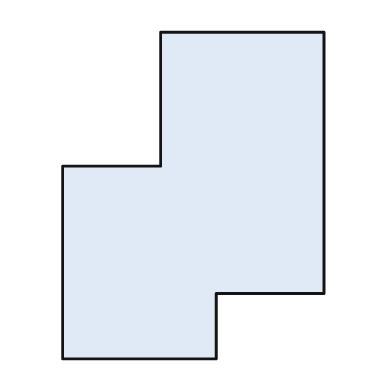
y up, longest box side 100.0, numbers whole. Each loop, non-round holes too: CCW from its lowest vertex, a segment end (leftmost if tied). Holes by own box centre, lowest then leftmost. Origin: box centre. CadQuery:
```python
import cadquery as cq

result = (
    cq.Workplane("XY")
    .moveTo(-40.0, -50.0)
    .lineTo(7.0, -50.0)
    .lineTo(7.0, -30.0)
    .lineTo(40.0, -30.0)
    .lineTo(40.0, 50.0)
    .lineTo(-10.0, 50.0)
    .lineTo(-10.0, 9.0)
    .lineTo(-40.0, 9.0)
    .close()
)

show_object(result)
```